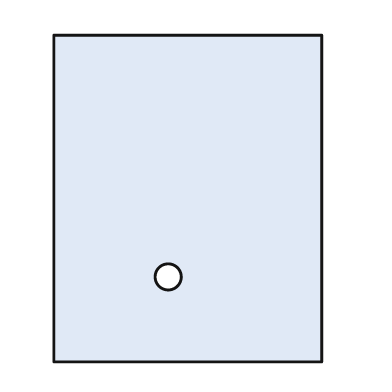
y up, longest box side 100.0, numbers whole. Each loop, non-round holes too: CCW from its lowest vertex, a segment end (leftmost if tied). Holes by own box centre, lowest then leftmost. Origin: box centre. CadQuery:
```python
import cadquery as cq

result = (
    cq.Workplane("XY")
    .moveTo(-41.0, -50.0)
    .lineTo(41.0, -50.0)
    .lineTo(41.0, 50.0)
    .lineTo(-41.0, 50.0)
    .close()
    .moveTo(-6.0, -24.0)
    .circle(4.0)
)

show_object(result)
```